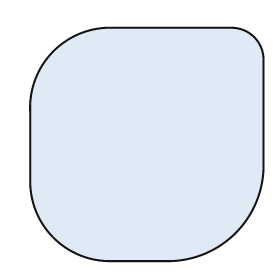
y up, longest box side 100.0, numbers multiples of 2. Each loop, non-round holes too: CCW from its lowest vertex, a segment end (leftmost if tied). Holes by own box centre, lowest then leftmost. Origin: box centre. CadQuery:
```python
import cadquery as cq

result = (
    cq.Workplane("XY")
    .moveTo(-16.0, -50.0)
    .lineTo(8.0, -50.0)
    .threePointArc((38.0, -38.0), (50.0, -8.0))
    .lineTo(50.0, 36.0)
    .threePointArc((46.0, 46.0), (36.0, 50.0))
    .lineTo(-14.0, 50.0)
    .threePointArc((-40.0, 40.0), (-50.0, 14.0))
    .lineTo(-50.0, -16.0)
    .threePointArc((-40.0, -40.0), (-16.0, -50.0))
    .close()
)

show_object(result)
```